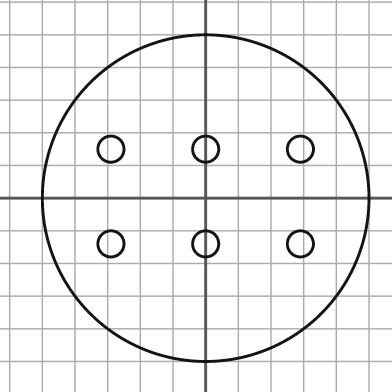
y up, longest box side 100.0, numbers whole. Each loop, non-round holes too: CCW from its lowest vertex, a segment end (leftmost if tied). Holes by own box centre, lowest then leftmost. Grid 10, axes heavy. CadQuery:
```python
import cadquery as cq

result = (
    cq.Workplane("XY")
    .moveTo(0.0, 0.0)
    .circle(50.0)
    .moveTo(-29.0, -14.0)
    .circle(4.0)
    .moveTo(0.0, -14.0)
    .circle(4.0)
    .moveTo(29.0, -14.0)
    .circle(4.0)
    .moveTo(-29.0, 15.0)
    .circle(4.0)
    .moveTo(0.0, 15.0)
    .circle(4.0)
    .moveTo(29.0, 15.0)
    .circle(4.0)
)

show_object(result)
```